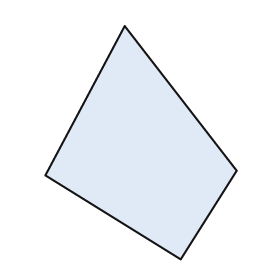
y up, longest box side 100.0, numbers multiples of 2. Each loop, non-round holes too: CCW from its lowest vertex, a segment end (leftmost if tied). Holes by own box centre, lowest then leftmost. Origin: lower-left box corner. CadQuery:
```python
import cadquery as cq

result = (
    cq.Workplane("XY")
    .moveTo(58.0, 0.0)
    .lineTo(82.0, 38.0)
    .lineTo(34.0, 100.0)
    .lineTo(0.0, 36.0)
    .close()
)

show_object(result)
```